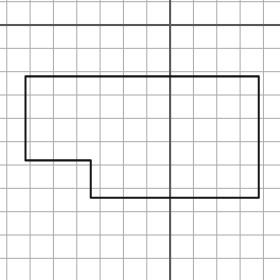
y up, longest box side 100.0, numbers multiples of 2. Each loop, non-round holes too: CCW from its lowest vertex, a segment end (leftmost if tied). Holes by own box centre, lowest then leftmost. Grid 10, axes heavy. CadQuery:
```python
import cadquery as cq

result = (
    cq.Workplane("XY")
    .moveTo(-34.0, -74.0)
    .lineTo(38.0, -74.0)
    .lineTo(38.0, -22.0)
    .lineTo(-62.0, -22.0)
    .lineTo(-62.0, -58.0)
    .lineTo(-34.0, -58.0)
    .close()
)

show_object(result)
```